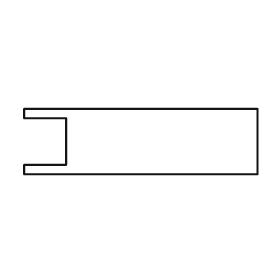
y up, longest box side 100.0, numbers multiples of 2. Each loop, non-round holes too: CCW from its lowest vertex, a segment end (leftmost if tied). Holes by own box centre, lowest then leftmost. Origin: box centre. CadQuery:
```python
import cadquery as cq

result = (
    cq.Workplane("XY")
    .moveTo(-50.0, -14.0)
    .lineTo(50.0, -14.0)
    .lineTo(50.0, 14.0)
    .lineTo(-50.0, 14.0)
    .lineTo(-50.0, 10.0)
    .lineTo(-32.0, 10.0)
    .lineTo(-32.0, -10.0)
    .lineTo(-50.0, -10.0)
    .close()
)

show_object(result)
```